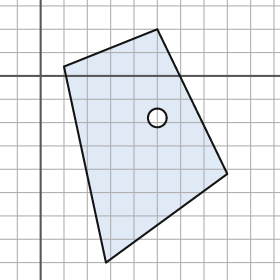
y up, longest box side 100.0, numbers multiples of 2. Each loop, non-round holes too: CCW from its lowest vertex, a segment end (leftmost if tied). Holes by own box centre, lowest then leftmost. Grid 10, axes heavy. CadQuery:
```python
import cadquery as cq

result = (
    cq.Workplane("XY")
    .moveTo(28.0, -80.0)
    .lineTo(80.0, -42.0)
    .lineTo(50.0, 20.0)
    .lineTo(10.0, 4.0)
    .close()
    .moveTo(50.0, -18.0)
    .circle(4.0)
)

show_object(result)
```